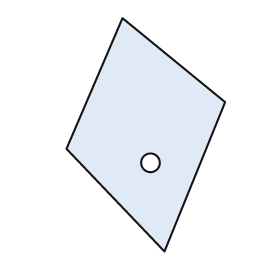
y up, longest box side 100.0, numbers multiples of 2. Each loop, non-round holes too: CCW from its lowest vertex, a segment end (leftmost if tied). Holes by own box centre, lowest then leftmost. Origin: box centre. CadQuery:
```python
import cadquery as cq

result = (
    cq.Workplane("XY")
    .moveTo(8.0, -50.0)
    .lineTo(34.0, 14.0)
    .lineTo(-10.0, 50.0)
    .lineTo(-34.0, -6.0)
    .close()
    .moveTo(2.0, -12.0)
    .circle(4.0)
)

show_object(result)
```